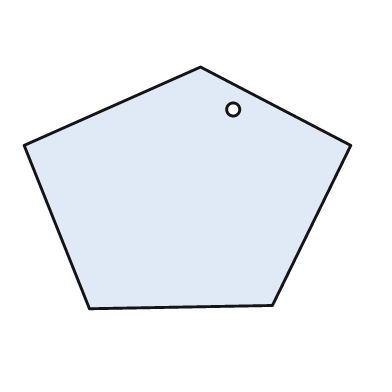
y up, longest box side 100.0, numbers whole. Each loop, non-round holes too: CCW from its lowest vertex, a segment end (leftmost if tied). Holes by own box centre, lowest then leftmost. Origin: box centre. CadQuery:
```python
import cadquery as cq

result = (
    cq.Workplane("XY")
    .moveTo(-30.0, -37.0)
    .lineTo(26.0, -36.0)
    .lineTo(50.0, 13.0)
    .lineTo(4.0, 37.0)
    .lineTo(-50.0, 13.0)
    .close()
    .moveTo(14.0, 24.0)
    .circle(2.0)
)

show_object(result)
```